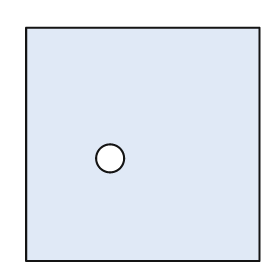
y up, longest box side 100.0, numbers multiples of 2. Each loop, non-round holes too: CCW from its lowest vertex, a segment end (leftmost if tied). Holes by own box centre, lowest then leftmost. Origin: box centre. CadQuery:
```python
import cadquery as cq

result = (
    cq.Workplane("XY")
    .moveTo(-50.0, -50.0)
    .lineTo(50.0, -50.0)
    .lineTo(50.0, 50.0)
    .lineTo(-50.0, 50.0)
    .close()
    .moveTo(-14.0, -6.0)
    .circle(6.0)
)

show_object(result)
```